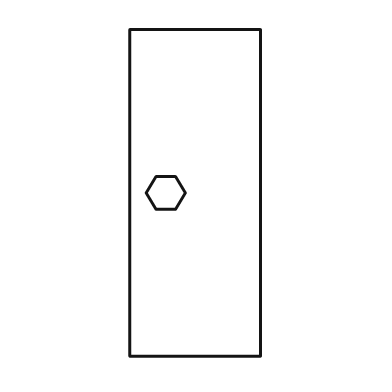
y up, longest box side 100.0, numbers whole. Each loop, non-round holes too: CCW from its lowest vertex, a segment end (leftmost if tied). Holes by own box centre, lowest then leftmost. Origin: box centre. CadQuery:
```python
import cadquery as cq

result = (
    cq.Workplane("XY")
    .moveTo(-20.0, -50.0)
    .lineTo(20.0, -50.0)
    .lineTo(20.0, 50.0)
    .lineTo(-20.0, 50.0)
    .close()
    .moveTo(-12.0, -5.0)
    .lineTo(-6.0, -5.0)
    .lineTo(-3.0, 0.0)
    .lineTo(-6.0, 5.0)
    .lineTo(-12.0, 5.0)
    .lineTo(-15.0, 0.0)
    .close()
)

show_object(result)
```